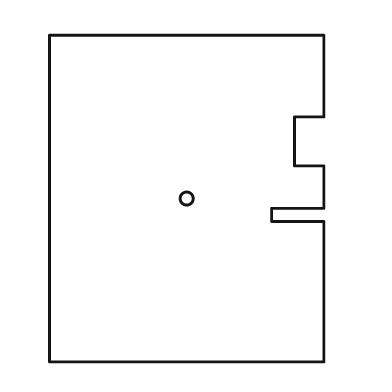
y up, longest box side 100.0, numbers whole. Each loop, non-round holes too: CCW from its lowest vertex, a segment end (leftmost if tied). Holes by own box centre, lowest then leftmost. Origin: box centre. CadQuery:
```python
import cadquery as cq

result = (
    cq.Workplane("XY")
    .moveTo(-42.0, -50.0)
    .lineTo(42.0, -50.0)
    .lineTo(42.0, -7.0)
    .lineTo(26.0, -7.0)
    .lineTo(26.0, -3.0)
    .lineTo(42.0, -3.0)
    .lineTo(42.0, 10.0)
    .lineTo(33.0, 10.0)
    .lineTo(33.0, 25.0)
    .lineTo(42.0, 25.0)
    .lineTo(42.0, 50.0)
    .lineTo(-42.0, 50.0)
    .close()
    .moveTo(0.0, 0.0)
    .circle(2.0)
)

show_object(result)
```